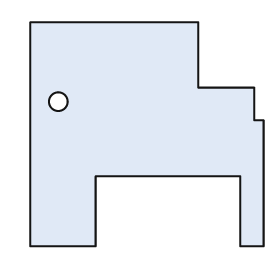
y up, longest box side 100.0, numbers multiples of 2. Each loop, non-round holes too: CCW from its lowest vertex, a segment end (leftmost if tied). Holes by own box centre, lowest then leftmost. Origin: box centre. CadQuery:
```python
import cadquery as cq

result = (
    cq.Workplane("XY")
    .moveTo(-50.0, -48.0)
    .lineTo(-22.0, -48.0)
    .lineTo(-22.0, -18.0)
    .lineTo(40.0, -18.0)
    .lineTo(40.0, -48.0)
    .lineTo(50.0, -48.0)
    .lineTo(50.0, 6.0)
    .lineTo(46.0, 6.0)
    .lineTo(46.0, 20.0)
    .lineTo(22.0, 20.0)
    .lineTo(22.0, 48.0)
    .lineTo(-50.0, 48.0)
    .close()
    .moveTo(-38.0, 14.0)
    .circle(4.0)
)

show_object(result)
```